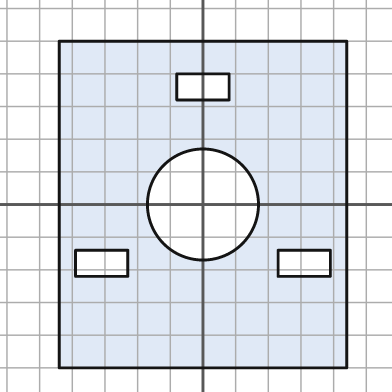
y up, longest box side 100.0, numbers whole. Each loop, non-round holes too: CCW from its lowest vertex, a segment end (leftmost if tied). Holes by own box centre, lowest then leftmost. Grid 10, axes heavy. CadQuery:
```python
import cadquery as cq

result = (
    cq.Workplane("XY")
    .moveTo(-44.0, -50.0)
    .lineTo(44.0, -50.0)
    .lineTo(44.0, 50.0)
    .lineTo(-44.0, 50.0)
    .close()
    .moveTo(-39.0, -22.0)
    .lineTo(-23.0, -22.0)
    .lineTo(-23.0, -14.0)
    .lineTo(-39.0, -14.0)
    .close()
    .moveTo(23.0, -22.0)
    .lineTo(39.0, -22.0)
    .lineTo(39.0, -14.0)
    .lineTo(23.0, -14.0)
    .close()
    .moveTo(0.0, 0.0)
    .circle(17.0)
    .moveTo(-8.0, 32.0)
    .lineTo(8.0, 32.0)
    .lineTo(8.0, 40.0)
    .lineTo(-8.0, 40.0)
    .close()
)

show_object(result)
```